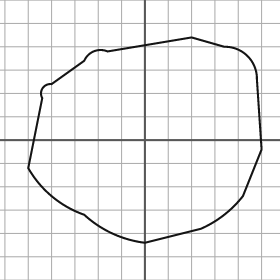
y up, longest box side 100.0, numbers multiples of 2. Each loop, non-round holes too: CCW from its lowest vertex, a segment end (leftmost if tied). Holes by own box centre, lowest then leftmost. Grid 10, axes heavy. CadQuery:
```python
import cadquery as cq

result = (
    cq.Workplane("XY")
    .moveTo(0.0, -44.0)
    .lineTo(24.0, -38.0)
    .threePointArc((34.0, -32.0), (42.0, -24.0))
    .lineTo(50.0, -4.0)
    .lineTo(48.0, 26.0)
    .threePointArc((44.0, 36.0), (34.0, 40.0))
    .lineTo(20.0, 44.0)
    .lineTo(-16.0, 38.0)
    .threePointArc((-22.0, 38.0), (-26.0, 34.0))
    .lineTo(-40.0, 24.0)
    .threePointArc((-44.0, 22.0), (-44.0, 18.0))
    .lineTo(-50.0, -12.0)
    .threePointArc((-40.0, -24.0), (-26.0, -32.0))
    .threePointArc((-14.0, -40.0), (0.0, -44.0))
    .close()
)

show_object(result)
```